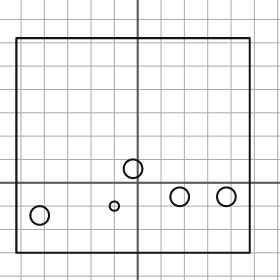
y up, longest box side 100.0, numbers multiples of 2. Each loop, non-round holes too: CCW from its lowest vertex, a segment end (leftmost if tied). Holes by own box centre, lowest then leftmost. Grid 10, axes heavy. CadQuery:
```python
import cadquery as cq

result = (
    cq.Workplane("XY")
    .moveTo(-52.0, -30.0)
    .lineTo(48.0, -30.0)
    .lineTo(48.0, 62.0)
    .lineTo(-52.0, 62.0)
    .close()
    .moveTo(-42.0, -14.0)
    .circle(4.0)
    .moveTo(-10.0, -10.0)
    .circle(2.0)
    .moveTo(18.0, -6.0)
    .circle(4.0)
    .moveTo(38.0, -6.0)
    .circle(4.0)
    .moveTo(-2.0, 6.0)
    .circle(4.0)
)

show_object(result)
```